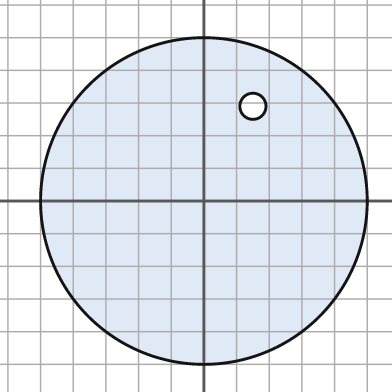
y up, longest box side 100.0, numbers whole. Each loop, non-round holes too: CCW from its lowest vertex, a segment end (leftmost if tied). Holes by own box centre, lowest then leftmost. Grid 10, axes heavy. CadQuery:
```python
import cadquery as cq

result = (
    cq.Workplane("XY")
    .moveTo(0.0, 0.0)
    .circle(50.0)
    .moveTo(15.0, 29.0)
    .circle(4.0)
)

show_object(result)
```